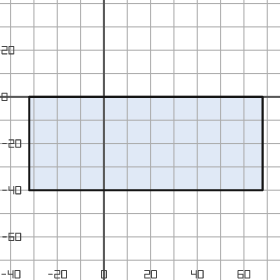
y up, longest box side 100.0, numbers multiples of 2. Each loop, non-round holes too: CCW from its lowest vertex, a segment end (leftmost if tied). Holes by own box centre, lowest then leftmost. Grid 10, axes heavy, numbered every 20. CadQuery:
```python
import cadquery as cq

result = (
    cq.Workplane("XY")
    .moveTo(-32.0, -40.0)
    .lineTo(68.0, -40.0)
    .lineTo(68.0, 0.0)
    .lineTo(-32.0, 0.0)
    .close()
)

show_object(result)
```